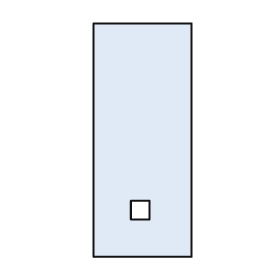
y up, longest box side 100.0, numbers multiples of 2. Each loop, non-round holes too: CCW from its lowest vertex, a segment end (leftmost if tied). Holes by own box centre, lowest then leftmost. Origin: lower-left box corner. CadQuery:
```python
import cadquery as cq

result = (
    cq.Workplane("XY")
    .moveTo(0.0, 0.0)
    .lineTo(42.0, 0.0)
    .lineTo(42.0, 100.0)
    .lineTo(0.0, 100.0)
    .close()
    .moveTo(16.0, 16.0)
    .lineTo(24.0, 16.0)
    .lineTo(24.0, 24.0)
    .lineTo(16.0, 24.0)
    .close()
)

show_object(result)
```